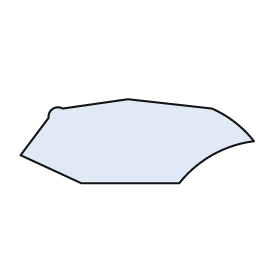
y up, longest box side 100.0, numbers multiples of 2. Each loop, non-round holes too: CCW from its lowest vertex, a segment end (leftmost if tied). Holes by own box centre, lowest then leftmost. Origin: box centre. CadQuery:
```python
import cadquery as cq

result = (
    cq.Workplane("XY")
    .moveTo(-24.0, -18.0)
    .lineTo(18.0, -18.0)
    .threePointArc((32.0, -6.0), (50.0, 0.0))
    .threePointArc((42.0, 8.0), (32.0, 14.0))
    .lineTo(-4.0, 18.0)
    .lineTo(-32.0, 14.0)
    .threePointArc((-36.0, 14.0), (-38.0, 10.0))
    .lineTo(-50.0, -6.0)
    .close()
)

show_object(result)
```